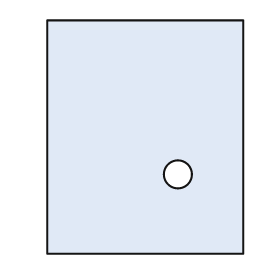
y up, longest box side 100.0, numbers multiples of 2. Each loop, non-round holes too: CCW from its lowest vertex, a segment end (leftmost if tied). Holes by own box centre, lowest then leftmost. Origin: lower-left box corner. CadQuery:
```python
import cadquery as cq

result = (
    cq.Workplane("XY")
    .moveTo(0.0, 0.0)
    .lineTo(84.0, 0.0)
    .lineTo(84.0, 100.0)
    .lineTo(0.0, 100.0)
    .close()
    .moveTo(56.0, 34.0)
    .circle(6.0)
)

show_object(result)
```